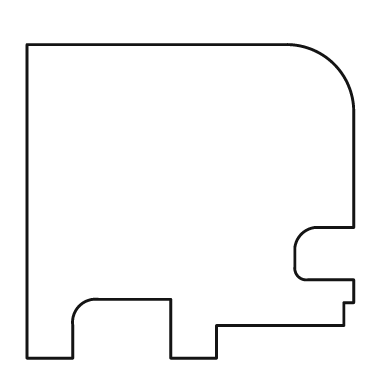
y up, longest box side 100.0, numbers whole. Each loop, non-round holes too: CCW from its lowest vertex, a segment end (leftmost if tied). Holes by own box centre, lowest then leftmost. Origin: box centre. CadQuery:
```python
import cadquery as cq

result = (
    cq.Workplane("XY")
    .moveTo(-50.0, -48.0)
    .lineTo(-36.0, -48.0)
    .lineTo(-36.0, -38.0)
    .threePointArc((-34.0, -32.0), (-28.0, -30.0))
    .lineTo(-6.0, -30.0)
    .lineTo(-6.0, -48.0)
    .lineTo(8.0, -48.0)
    .lineTo(8.0, -38.0)
    .lineTo(47.0, -38.0)
    .lineTo(47.0, -31.0)
    .lineTo(50.0, -31.0)
    .lineTo(50.0, -24.0)
    .lineTo(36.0, -24.0)
    .threePointArc((33.0, -23.0), (32.0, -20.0))
    .lineTo(32.0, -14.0)
    .threePointArc((34.0, -10.0), (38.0, -8.0))
    .lineTo(50.0, -8.0)
    .lineTo(50.0, 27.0)
    .threePointArc((44.0, 42.0), (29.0, 48.0))
    .lineTo(-50.0, 48.0)
    .close()
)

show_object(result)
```